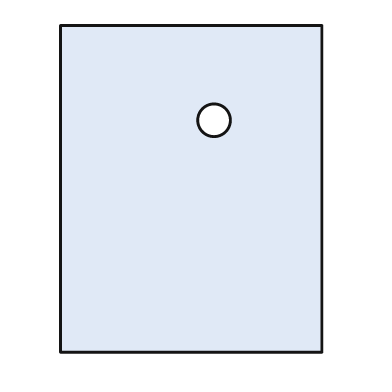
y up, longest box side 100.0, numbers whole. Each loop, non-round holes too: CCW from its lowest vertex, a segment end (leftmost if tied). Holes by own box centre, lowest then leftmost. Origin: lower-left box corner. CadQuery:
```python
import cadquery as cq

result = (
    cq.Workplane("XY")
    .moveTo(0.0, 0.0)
    .lineTo(80.0, 0.0)
    .lineTo(80.0, 100.0)
    .lineTo(0.0, 100.0)
    .close()
    .moveTo(47.0, 71.0)
    .circle(5.0)
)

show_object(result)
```